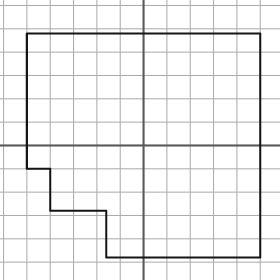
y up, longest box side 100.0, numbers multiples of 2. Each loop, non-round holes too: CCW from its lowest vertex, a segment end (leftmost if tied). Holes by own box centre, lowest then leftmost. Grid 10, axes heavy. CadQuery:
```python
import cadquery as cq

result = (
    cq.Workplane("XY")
    .moveTo(-16.0, -48.0)
    .lineTo(50.0, -48.0)
    .lineTo(50.0, 48.0)
    .lineTo(-50.0, 48.0)
    .lineTo(-50.0, -10.0)
    .lineTo(-40.0, -10.0)
    .lineTo(-40.0, -28.0)
    .lineTo(-16.0, -28.0)
    .close()
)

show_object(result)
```